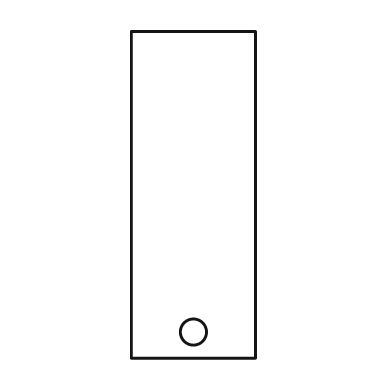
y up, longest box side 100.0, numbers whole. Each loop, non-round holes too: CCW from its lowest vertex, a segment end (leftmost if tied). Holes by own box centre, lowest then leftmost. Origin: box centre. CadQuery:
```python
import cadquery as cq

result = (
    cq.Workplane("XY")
    .moveTo(-19.0, -50.0)
    .lineTo(19.0, -50.0)
    .lineTo(19.0, 50.0)
    .lineTo(-19.0, 50.0)
    .close()
    .moveTo(0.0, -42.0)
    .circle(4.0)
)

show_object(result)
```